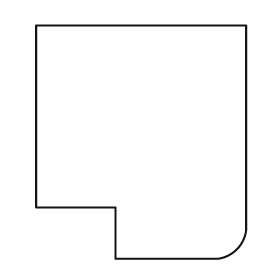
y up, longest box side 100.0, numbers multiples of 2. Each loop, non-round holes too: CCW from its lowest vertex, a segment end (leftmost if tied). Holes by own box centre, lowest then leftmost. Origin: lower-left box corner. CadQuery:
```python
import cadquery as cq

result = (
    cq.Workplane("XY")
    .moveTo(34.0, 0.0)
    .lineTo(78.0, 0.0)
    .threePointArc((86.0, 4.0), (90.0, 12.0))
    .lineTo(90.0, 100.0)
    .lineTo(0.0, 100.0)
    .lineTo(0.0, 22.0)
    .lineTo(34.0, 22.0)
    .close()
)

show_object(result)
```